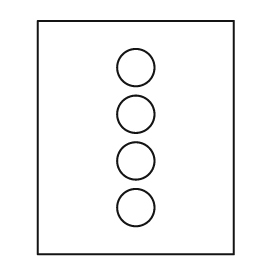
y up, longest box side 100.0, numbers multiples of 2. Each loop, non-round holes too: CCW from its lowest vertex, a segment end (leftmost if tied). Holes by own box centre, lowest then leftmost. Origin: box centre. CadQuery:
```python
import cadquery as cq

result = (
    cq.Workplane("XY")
    .moveTo(-42.0, -50.0)
    .lineTo(42.0, -50.0)
    .lineTo(42.0, 50.0)
    .lineTo(-42.0, 50.0)
    .close()
    .moveTo(0.0, -30.0)
    .circle(8.0)
    .moveTo(0.0, -10.0)
    .circle(8.0)
    .moveTo(0.0, 10.0)
    .circle(8.0)
    .moveTo(0.0, 30.0)
    .circle(8.0)
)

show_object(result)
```